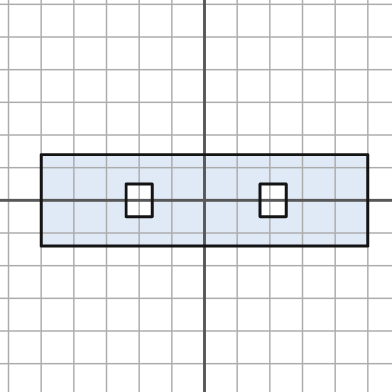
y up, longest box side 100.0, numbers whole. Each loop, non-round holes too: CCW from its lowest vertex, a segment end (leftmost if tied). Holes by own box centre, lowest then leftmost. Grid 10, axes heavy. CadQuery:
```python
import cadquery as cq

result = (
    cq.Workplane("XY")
    .moveTo(-50.0, -14.0)
    .lineTo(50.0, -14.0)
    .lineTo(50.0, 14.0)
    .lineTo(-50.0, 14.0)
    .close()
    .moveTo(-24.0, -5.0)
    .lineTo(-16.0, -5.0)
    .lineTo(-16.0, 5.0)
    .lineTo(-24.0, 5.0)
    .close()
    .moveTo(17.0, -5.0)
    .lineTo(25.0, -5.0)
    .lineTo(25.0, 5.0)
    .lineTo(17.0, 5.0)
    .close()
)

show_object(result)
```